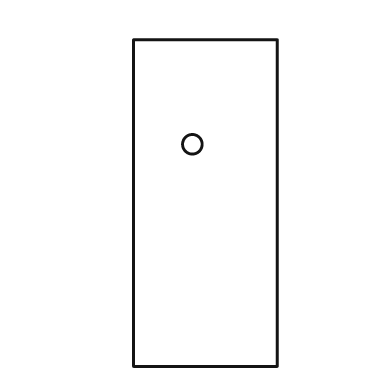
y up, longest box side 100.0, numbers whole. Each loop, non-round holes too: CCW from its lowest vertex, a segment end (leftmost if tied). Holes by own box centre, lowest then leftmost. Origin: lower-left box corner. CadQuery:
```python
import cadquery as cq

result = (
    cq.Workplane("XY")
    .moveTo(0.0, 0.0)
    .lineTo(44.0, 0.0)
    .lineTo(44.0, 100.0)
    .lineTo(0.0, 100.0)
    .close()
    .moveTo(18.0, 68.0)
    .circle(3.0)
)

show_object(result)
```